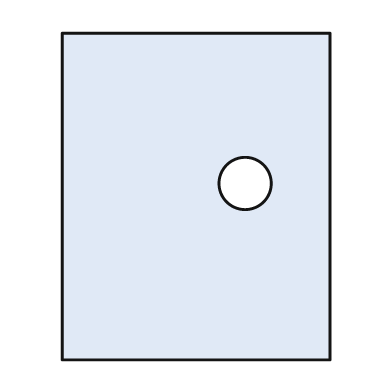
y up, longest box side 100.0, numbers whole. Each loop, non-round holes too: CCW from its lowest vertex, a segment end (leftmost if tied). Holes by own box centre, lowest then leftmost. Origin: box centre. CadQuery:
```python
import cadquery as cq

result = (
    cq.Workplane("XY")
    .moveTo(-41.0, -50.0)
    .lineTo(41.0, -50.0)
    .lineTo(41.0, 50.0)
    .lineTo(-41.0, 50.0)
    .close()
    .moveTo(15.0, 4.0)
    .circle(8.0)
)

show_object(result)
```